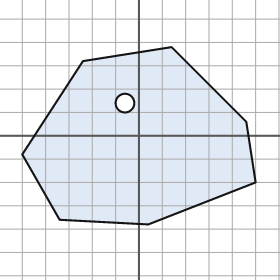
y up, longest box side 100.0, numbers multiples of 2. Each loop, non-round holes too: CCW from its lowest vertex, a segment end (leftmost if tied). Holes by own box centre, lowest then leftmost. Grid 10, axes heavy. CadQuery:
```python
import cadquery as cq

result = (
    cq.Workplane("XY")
    .moveTo(4.0, -38.0)
    .lineTo(50.0, -20.0)
    .lineTo(46.0, 6.0)
    .lineTo(14.0, 38.0)
    .lineTo(-24.0, 32.0)
    .lineTo(-50.0, -8.0)
    .lineTo(-34.0, -36.0)
    .close()
    .moveTo(-6.0, 14.0)
    .circle(4.0)
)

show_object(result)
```